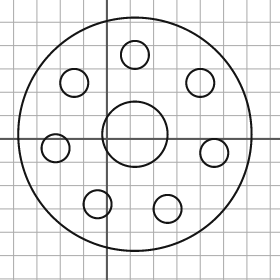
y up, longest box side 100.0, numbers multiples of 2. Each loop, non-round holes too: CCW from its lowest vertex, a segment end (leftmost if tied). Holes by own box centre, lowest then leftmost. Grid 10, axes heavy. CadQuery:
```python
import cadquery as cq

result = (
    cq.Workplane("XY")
    .moveTo(12.0, 2.0)
    .circle(50.0)
    .moveTo(26.0, -30.0)
    .circle(6.0)
    .moveTo(-4.0, -28.0)
    .circle(6.0)
    .moveTo(46.0, -6.0)
    .circle(6.0)
    .moveTo(-22.0, -4.0)
    .circle(6.0)
    .moveTo(12.0, 2.0)
    .circle(14.0)
    .moveTo(-14.0, 24.0)
    .circle(6.0)
    .moveTo(40.0, 24.0)
    .circle(6.0)
    .moveTo(12.0, 36.0)
    .circle(6.0)
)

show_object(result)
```